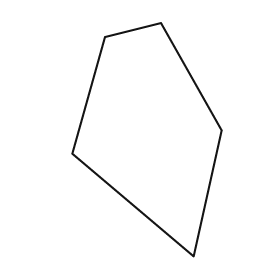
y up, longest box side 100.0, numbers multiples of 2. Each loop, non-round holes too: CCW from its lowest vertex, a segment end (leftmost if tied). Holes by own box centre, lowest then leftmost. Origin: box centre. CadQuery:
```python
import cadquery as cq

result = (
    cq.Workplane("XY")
    .moveTo(20.0, -50.0)
    .lineTo(32.0, 4.0)
    .lineTo(6.0, 50.0)
    .lineTo(-18.0, 44.0)
    .lineTo(-32.0, -6.0)
    .close()
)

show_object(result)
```